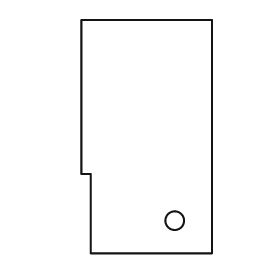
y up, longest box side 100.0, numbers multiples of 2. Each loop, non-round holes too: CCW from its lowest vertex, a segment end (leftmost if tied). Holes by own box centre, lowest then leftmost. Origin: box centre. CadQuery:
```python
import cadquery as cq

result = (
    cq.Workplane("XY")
    .moveTo(-24.0, -50.0)
    .lineTo(28.0, -50.0)
    .lineTo(28.0, 50.0)
    .lineTo(-28.0, 50.0)
    .lineTo(-28.0, -16.0)
    .lineTo(-24.0, -16.0)
    .close()
    .moveTo(12.0, -36.0)
    .circle(4.0)
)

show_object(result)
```